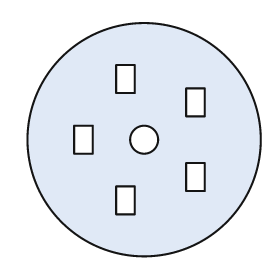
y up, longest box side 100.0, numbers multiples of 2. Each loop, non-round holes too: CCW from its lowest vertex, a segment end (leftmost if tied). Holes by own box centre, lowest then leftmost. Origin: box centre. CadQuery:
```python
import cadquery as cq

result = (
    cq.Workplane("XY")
    .moveTo(0.0, 0.0)
    .circle(50.0)
    .moveTo(-12.0, -32.0)
    .lineTo(-4.0, -32.0)
    .lineTo(-4.0, -20.0)
    .lineTo(-12.0, -20.0)
    .close()
    .moveTo(18.0, -22.0)
    .lineTo(26.0, -22.0)
    .lineTo(26.0, -10.0)
    .lineTo(18.0, -10.0)
    .close()
    .moveTo(-30.0, -6.0)
    .lineTo(-22.0, -6.0)
    .lineTo(-22.0, 6.0)
    .lineTo(-30.0, 6.0)
    .close()
    .moveTo(0.0, 0.0)
    .circle(6.0)
    .moveTo(18.0, 10.0)
    .lineTo(26.0, 10.0)
    .lineTo(26.0, 22.0)
    .lineTo(18.0, 22.0)
    .close()
    .moveTo(-12.0, 20.0)
    .lineTo(-4.0, 20.0)
    .lineTo(-4.0, 32.0)
    .lineTo(-12.0, 32.0)
    .close()
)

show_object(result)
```